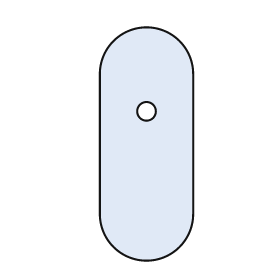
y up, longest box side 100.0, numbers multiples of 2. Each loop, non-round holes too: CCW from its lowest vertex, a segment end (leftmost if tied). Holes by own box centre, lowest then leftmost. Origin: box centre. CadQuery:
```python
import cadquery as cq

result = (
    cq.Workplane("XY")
    .moveTo(-20.0, -30.0)
    .threePointArc((0.0, -50.0), (20.0, -30.0))
    .lineTo(20.0, 30.0)
    .threePointArc((0.0, 50.0), (-20.0, 30.0))
    .close()
    .moveTo(0.0, 14.0)
    .circle(4.0)
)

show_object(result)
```